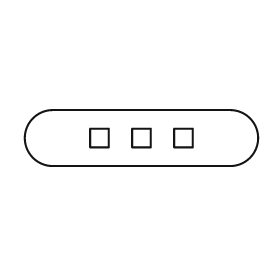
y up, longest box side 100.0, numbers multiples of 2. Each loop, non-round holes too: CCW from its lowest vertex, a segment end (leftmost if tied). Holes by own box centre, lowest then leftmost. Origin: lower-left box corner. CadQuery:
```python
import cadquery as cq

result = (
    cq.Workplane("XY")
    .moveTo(12.0, 0.0)
    .lineTo(88.0, 0.0)
    .threePointArc((100.0, 12.0), (88.0, 24.0))
    .lineTo(12.0, 24.0)
    .threePointArc((0.0, 12.0), (12.0, 0.0))
    .close()
    .moveTo(28.0, 8.0)
    .lineTo(36.0, 8.0)
    .lineTo(36.0, 16.0)
    .lineTo(28.0, 16.0)
    .close()
    .moveTo(46.0, 8.0)
    .lineTo(54.0, 8.0)
    .lineTo(54.0, 16.0)
    .lineTo(46.0, 16.0)
    .close()
    .moveTo(64.0, 8.0)
    .lineTo(72.0, 8.0)
    .lineTo(72.0, 16.0)
    .lineTo(64.0, 16.0)
    .close()
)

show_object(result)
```